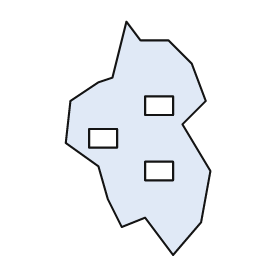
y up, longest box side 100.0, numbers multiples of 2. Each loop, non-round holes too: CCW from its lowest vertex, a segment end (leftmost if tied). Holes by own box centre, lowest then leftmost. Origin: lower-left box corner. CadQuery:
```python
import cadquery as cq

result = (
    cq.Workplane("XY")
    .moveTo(46.0, 0.0)
    .lineTo(58.0, 14.0)
    .lineTo(62.0, 36.0)
    .lineTo(50.0, 56.0)
    .lineTo(60.0, 66.0)
    .lineTo(54.0, 82.0)
    .lineTo(44.0, 92.0)
    .lineTo(32.0, 92.0)
    .lineTo(26.0, 100.0)
    .lineTo(20.0, 76.0)
    .lineTo(14.0, 74.0)
    .lineTo(2.0, 66.0)
    .lineTo(0.0, 48.0)
    .lineTo(14.0, 38.0)
    .lineTo(18.0, 24.0)
    .lineTo(24.0, 12.0)
    .lineTo(34.0, 16.0)
    .close()
    .moveTo(34.0, 32.0)
    .lineTo(46.0, 32.0)
    .lineTo(46.0, 40.0)
    .lineTo(34.0, 40.0)
    .close()
    .moveTo(10.0, 46.0)
    .lineTo(22.0, 46.0)
    .lineTo(22.0, 54.0)
    .lineTo(10.0, 54.0)
    .close()
    .moveTo(34.0, 60.0)
    .lineTo(46.0, 60.0)
    .lineTo(46.0, 68.0)
    .lineTo(34.0, 68.0)
    .close()
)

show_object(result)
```